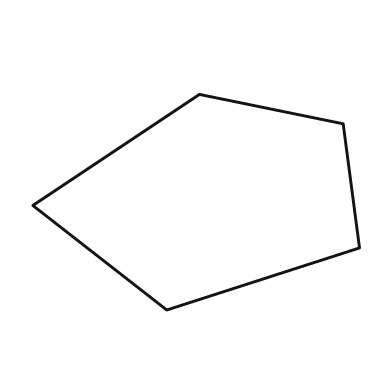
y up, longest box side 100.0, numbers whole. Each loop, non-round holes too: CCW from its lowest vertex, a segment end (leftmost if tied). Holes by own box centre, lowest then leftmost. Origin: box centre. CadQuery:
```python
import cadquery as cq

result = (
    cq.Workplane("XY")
    .moveTo(-9.0, -33.0)
    .lineTo(50.0, -14.0)
    .lineTo(45.0, 24.0)
    .lineTo(1.0, 33.0)
    .lineTo(-50.0, -1.0)
    .close()
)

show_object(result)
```